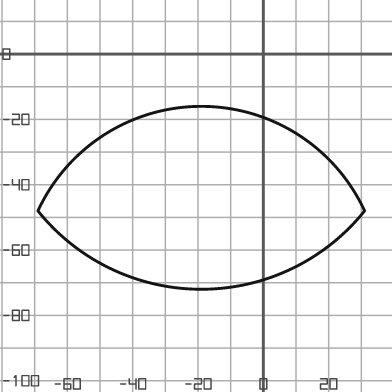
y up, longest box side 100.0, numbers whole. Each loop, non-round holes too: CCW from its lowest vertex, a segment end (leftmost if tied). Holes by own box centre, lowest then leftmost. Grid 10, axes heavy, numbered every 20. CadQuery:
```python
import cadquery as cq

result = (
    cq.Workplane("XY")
    .moveTo(-69.0, -48.0)
    .threePointArc((-19.0, -72.0), (31.0, -48.0))
    .threePointArc((-19.0, -16.0), (-69.0, -48.0))
    .close()
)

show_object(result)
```